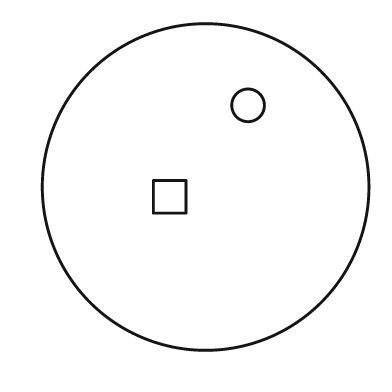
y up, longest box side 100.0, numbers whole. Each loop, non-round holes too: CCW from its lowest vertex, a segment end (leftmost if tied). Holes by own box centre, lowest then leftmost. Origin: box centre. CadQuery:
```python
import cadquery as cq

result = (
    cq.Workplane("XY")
    .moveTo(0.0, 0.0)
    .circle(50.0)
    .moveTo(-16.0, -8.0)
    .lineTo(-6.0, -8.0)
    .lineTo(-6.0, 2.0)
    .lineTo(-16.0, 2.0)
    .close()
    .moveTo(13.0, 25.0)
    .circle(5.0)
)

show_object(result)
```